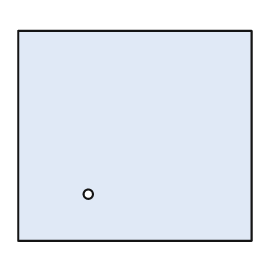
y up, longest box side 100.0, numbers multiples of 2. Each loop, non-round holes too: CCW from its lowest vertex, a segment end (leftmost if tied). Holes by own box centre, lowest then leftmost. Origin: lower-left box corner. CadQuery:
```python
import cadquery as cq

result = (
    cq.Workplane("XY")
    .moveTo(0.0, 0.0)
    .lineTo(100.0, 0.0)
    .lineTo(100.0, 90.0)
    .lineTo(0.0, 90.0)
    .close()
    .moveTo(30.0, 20.0)
    .circle(2.0)
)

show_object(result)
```